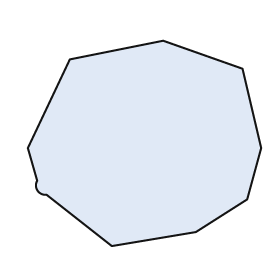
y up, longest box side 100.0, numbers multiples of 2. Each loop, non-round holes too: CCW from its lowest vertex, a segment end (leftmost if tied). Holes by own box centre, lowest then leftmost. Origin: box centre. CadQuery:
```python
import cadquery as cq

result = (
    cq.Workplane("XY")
    .moveTo(-14.0, -44.0)
    .lineTo(22.0, -38.0)
    .lineTo(44.0, -24.0)
    .lineTo(50.0, -2.0)
    .lineTo(42.0, 32.0)
    .lineTo(8.0, 44.0)
    .lineTo(-32.0, 36.0)
    .lineTo(-50.0, -2.0)
    .lineTo(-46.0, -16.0)
    .threePointArc((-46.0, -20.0), (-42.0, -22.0))
    .close()
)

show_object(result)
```